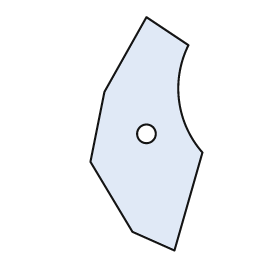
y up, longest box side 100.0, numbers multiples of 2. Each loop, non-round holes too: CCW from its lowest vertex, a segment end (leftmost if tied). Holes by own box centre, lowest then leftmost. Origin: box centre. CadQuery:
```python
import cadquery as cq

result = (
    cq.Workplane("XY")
    .moveTo(12.0, -50.0)
    .lineTo(24.0, -8.0)
    .threePointArc((14.0, 14.0), (18.0, 38.0))
    .lineTo(0.0, 50.0)
    .lineTo(-18.0, 18.0)
    .lineTo(-24.0, -12.0)
    .lineTo(-6.0, -42.0)
    .close()
    .moveTo(0.0, 0.0)
    .circle(4.0)
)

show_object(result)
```